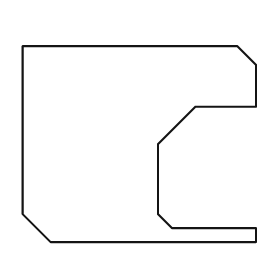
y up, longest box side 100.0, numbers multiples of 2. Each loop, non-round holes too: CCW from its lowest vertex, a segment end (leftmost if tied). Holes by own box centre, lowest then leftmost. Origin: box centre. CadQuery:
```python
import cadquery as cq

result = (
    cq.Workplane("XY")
    .moveTo(-38.0, -42.0)
    .lineTo(50.0, -42.0)
    .lineTo(50.0, -36.0)
    .lineTo(14.0, -36.0)
    .lineTo(8.0, -30.0)
    .lineTo(8.0, 0.0)
    .lineTo(24.0, 16.0)
    .lineTo(50.0, 16.0)
    .lineTo(50.0, 34.0)
    .lineTo(42.0, 42.0)
    .lineTo(-50.0, 42.0)
    .lineTo(-50.0, -30.0)
    .close()
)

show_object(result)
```